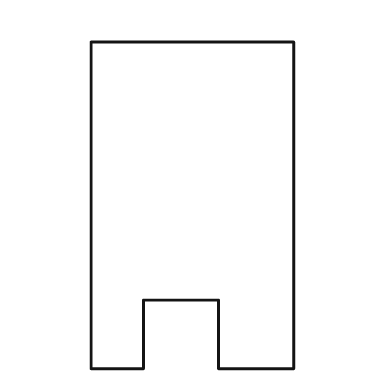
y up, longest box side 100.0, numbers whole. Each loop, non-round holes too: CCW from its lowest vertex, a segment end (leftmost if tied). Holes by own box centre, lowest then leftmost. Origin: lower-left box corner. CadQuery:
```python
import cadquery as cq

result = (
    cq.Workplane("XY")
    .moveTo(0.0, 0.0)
    .lineTo(16.0, 0.0)
    .lineTo(16.0, 21.0)
    .lineTo(39.0, 21.0)
    .lineTo(39.0, 0.0)
    .lineTo(62.0, 0.0)
    .lineTo(62.0, 100.0)
    .lineTo(0.0, 100.0)
    .close()
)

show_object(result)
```